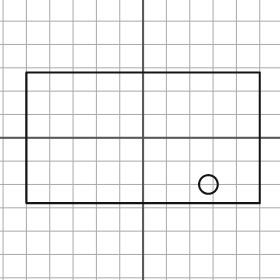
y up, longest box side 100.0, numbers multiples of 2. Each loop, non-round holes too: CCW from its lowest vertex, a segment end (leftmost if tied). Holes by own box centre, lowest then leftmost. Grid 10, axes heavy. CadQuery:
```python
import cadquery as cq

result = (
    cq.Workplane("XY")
    .moveTo(-50.0, -28.0)
    .lineTo(50.0, -28.0)
    .lineTo(50.0, 28.0)
    .lineTo(-50.0, 28.0)
    .close()
    .moveTo(28.0, -20.0)
    .circle(4.0)
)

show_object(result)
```